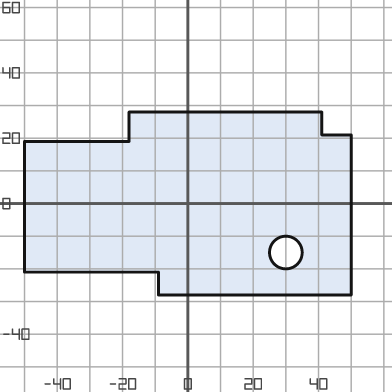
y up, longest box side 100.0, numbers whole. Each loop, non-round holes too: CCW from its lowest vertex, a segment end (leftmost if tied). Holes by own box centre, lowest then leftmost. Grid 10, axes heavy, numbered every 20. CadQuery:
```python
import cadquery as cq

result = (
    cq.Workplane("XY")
    .moveTo(-9.0, -28.0)
    .lineTo(50.0, -28.0)
    .lineTo(50.0, 21.0)
    .lineTo(41.0, 21.0)
    .lineTo(41.0, 28.0)
    .lineTo(-18.0, 28.0)
    .lineTo(-18.0, 19.0)
    .lineTo(-50.0, 19.0)
    .lineTo(-50.0, -21.0)
    .lineTo(-9.0, -21.0)
    .close()
    .moveTo(30.0, -15.0)
    .circle(5.0)
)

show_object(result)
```